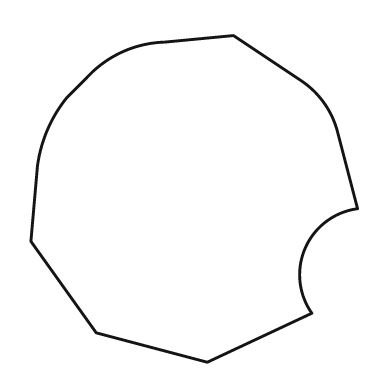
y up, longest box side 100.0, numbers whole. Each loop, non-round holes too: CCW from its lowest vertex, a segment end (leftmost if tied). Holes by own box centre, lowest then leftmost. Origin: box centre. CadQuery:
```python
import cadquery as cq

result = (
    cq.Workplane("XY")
    .moveTo(4.0, -50.0)
    .lineTo(36.0, -35.0)
    .threePointArc((34.0, -15.0), (50.0, -3.0))
    .lineTo(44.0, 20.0)
    .threePointArc((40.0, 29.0), (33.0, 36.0))
    .lineTo(12.0, 50.0)
    .lineTo(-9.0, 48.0)
    .threePointArc((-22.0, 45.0), (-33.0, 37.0))
    .lineTo(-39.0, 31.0)
    .threePointArc((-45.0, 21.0), (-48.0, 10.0))
    .lineTo(-50.0, -13.0)
    .lineTo(-30.0, -41.0)
    .close()
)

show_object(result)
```